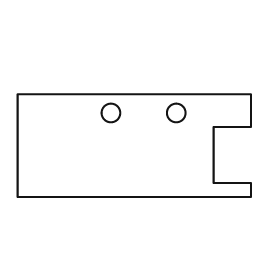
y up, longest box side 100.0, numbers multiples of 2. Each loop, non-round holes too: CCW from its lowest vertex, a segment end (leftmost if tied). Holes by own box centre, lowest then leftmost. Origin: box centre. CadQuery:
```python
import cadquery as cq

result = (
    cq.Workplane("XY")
    .moveTo(-50.0, -22.0)
    .lineTo(50.0, -22.0)
    .lineTo(50.0, -16.0)
    .lineTo(34.0, -16.0)
    .lineTo(34.0, 8.0)
    .lineTo(50.0, 8.0)
    .lineTo(50.0, 22.0)
    .lineTo(-50.0, 22.0)
    .close()
    .moveTo(-10.0, 14.0)
    .circle(4.0)
    .moveTo(18.0, 14.0)
    .circle(4.0)
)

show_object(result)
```